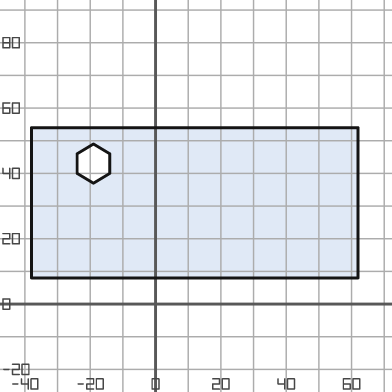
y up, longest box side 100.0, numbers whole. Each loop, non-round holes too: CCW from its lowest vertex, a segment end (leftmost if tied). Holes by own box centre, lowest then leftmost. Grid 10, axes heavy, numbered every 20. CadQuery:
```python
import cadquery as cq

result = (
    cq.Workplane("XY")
    .moveTo(-38.0, 8.0)
    .lineTo(62.0, 8.0)
    .lineTo(62.0, 54.0)
    .lineTo(-38.0, 54.0)
    .close()
    .moveTo(-19.0, 37.0)
    .lineTo(-14.0, 40.0)
    .lineTo(-14.0, 46.0)
    .lineTo(-19.0, 49.0)
    .lineTo(-24.0, 46.0)
    .lineTo(-24.0, 40.0)
    .close()
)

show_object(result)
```